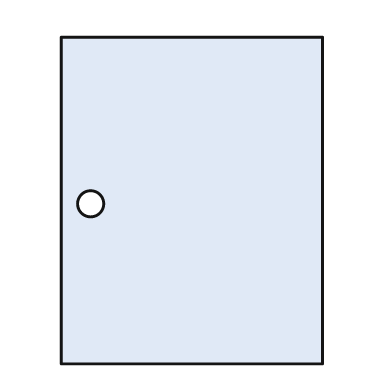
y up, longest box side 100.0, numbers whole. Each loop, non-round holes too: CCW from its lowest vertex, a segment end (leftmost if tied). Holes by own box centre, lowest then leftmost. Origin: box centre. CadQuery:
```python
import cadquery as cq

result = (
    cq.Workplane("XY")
    .moveTo(-40.0, -50.0)
    .lineTo(40.0, -50.0)
    .lineTo(40.0, 50.0)
    .lineTo(-40.0, 50.0)
    .close()
    .moveTo(-31.0, -1.0)
    .circle(4.0)
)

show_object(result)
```